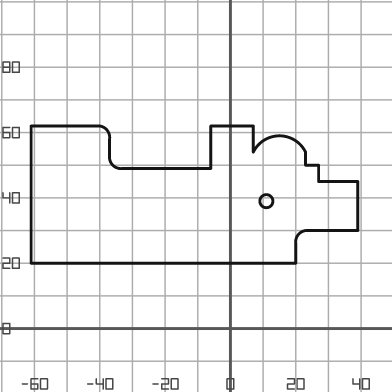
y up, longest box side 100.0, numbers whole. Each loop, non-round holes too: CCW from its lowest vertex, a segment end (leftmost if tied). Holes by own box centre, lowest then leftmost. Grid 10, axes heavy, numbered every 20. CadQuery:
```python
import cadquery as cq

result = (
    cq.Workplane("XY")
    .moveTo(-61.0, 20.0)
    .lineTo(20.0, 20.0)
    .lineTo(20.0, 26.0)
    .threePointArc((21.0, 29.0), (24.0, 30.0))
    .lineTo(39.0, 30.0)
    .lineTo(39.0, 45.0)
    .lineTo(27.0, 45.0)
    .lineTo(27.0, 50.0)
    .lineTo(23.0, 50.0)
    .lineTo(23.0, 54.0)
    .threePointArc((15.0, 59.0), (7.0, 54.0))
    .lineTo(7.0, 62.0)
    .lineTo(-6.0, 62.0)
    .lineTo(-6.0, 49.0)
    .lineTo(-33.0, 49.0)
    .threePointArc((-36.0, 50.0), (-37.0, 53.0))
    .lineTo(-37.0, 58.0)
    .threePointArc((-38.0, 61.0), (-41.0, 62.0))
    .lineTo(-61.0, 62.0)
    .close()
    .moveTo(11.0, 39.0)
    .circle(2.0)
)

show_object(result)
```